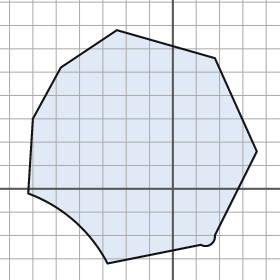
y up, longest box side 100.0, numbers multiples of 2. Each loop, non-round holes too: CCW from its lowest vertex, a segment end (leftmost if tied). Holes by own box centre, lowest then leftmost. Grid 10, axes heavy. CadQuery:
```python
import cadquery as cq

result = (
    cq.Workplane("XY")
    .moveTo(-28.0, -32.0)
    .lineTo(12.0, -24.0)
    .threePointArc((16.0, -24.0), (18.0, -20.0))
    .lineTo(36.0, 16.0)
    .lineTo(18.0, 56.0)
    .lineTo(-24.0, 68.0)
    .lineTo(-48.0, 52.0)
    .lineTo(-60.0, 30.0)
    .lineTo(-62.0, -2.0)
    .threePointArc((-42.0, -14.0), (-28.0, -32.0))
    .close()
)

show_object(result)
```